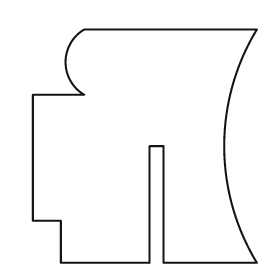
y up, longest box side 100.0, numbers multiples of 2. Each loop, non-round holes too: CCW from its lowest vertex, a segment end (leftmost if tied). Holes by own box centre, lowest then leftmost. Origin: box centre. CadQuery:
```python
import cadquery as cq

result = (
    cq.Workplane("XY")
    .moveTo(-36.0, -50.0)
    .lineTo(2.0, -50.0)
    .lineTo(2.0, 0.0)
    .lineTo(8.0, 0.0)
    .lineTo(8.0, -50.0)
    .lineTo(48.0, -50.0)
    .threePointArc((34.0, 0.0), (48.0, 50.0))
    .lineTo(-26.0, 50.0)
    .threePointArc((-34.0, 36.0), (-26.0, 22.0))
    .lineTo(-48.0, 22.0)
    .lineTo(-48.0, -32.0)
    .lineTo(-36.0, -32.0)
    .close()
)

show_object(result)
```